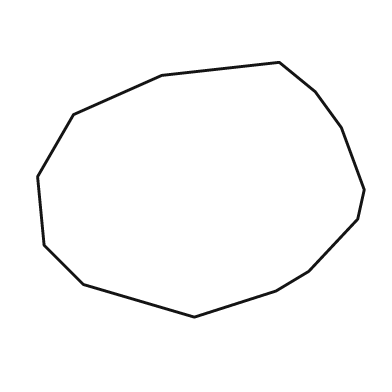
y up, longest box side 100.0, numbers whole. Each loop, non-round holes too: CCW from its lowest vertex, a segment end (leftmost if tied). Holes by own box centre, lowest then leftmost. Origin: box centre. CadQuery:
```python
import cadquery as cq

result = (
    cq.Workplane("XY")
    .moveTo(-2.0, -39.0)
    .lineTo(23.0, -31.0)
    .lineTo(33.0, -25.0)
    .lineTo(48.0, -9.0)
    .lineTo(50.0, 0.0)
    .lineTo(43.0, 19.0)
    .lineTo(35.0, 30.0)
    .lineTo(24.0, 39.0)
    .lineTo(-12.0, 35.0)
    .lineTo(-39.0, 23.0)
    .lineTo(-50.0, 4.0)
    .lineTo(-48.0, -17.0)
    .lineTo(-36.0, -29.0)
    .close()
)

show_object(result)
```